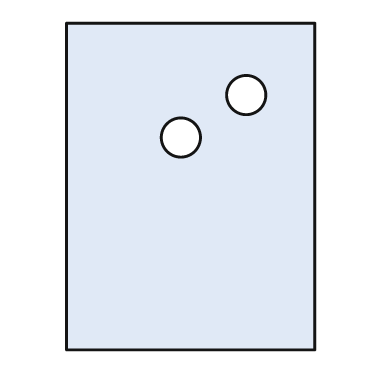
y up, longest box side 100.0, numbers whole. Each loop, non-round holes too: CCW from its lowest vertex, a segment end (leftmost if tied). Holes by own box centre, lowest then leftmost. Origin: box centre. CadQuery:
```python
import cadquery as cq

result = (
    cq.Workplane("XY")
    .moveTo(-38.0, -50.0)
    .lineTo(38.0, -50.0)
    .lineTo(38.0, 50.0)
    .lineTo(-38.0, 50.0)
    .close()
    .moveTo(-3.0, 15.0)
    .circle(6.0)
    .moveTo(17.0, 28.0)
    .circle(6.0)
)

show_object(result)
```